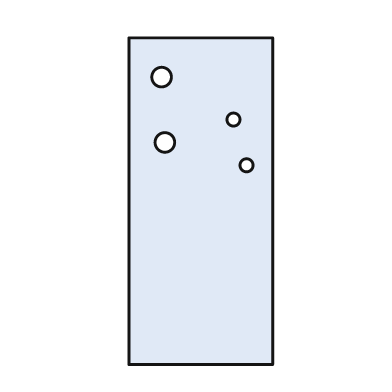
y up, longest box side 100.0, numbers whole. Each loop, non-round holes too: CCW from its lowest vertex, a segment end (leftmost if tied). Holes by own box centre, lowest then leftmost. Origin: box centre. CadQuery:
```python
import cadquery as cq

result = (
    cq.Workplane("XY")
    .moveTo(-22.0, -50.0)
    .lineTo(22.0, -50.0)
    .lineTo(22.0, 50.0)
    .lineTo(-22.0, 50.0)
    .close()
    .moveTo(14.0, 11.0)
    .circle(2.0)
    .moveTo(-11.0, 18.0)
    .circle(3.0)
    .moveTo(10.0, 25.0)
    .circle(2.0)
    .moveTo(-12.0, 38.0)
    .circle(3.0)
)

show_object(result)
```